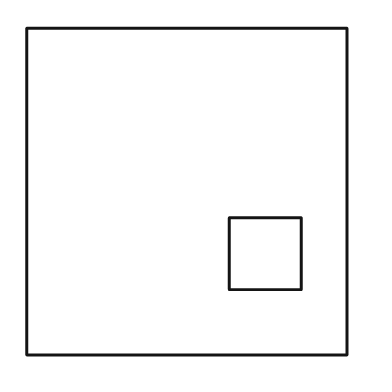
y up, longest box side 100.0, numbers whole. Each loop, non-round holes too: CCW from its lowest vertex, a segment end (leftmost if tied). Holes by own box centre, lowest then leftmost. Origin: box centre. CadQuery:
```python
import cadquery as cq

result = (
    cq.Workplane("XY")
    .moveTo(-49.0, -50.0)
    .lineTo(49.0, -50.0)
    .lineTo(49.0, 50.0)
    .lineTo(-49.0, 50.0)
    .close()
    .moveTo(13.0, -30.0)
    .lineTo(35.0, -30.0)
    .lineTo(35.0, -8.0)
    .lineTo(13.0, -8.0)
    .close()
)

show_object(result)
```